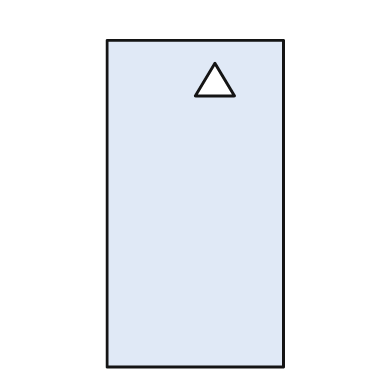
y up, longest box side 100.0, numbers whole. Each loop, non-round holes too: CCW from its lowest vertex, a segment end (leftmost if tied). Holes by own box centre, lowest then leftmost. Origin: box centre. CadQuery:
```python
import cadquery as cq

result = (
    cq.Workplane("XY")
    .moveTo(-27.0, -50.0)
    .lineTo(27.0, -50.0)
    .lineTo(27.0, 50.0)
    .lineTo(-27.0, 50.0)
    .close()
    .moveTo(0.0, 33.0)
    .lineTo(12.0, 33.0)
    .lineTo(6.0, 43.0)
    .close()
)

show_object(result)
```